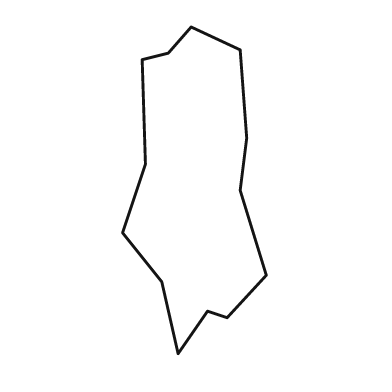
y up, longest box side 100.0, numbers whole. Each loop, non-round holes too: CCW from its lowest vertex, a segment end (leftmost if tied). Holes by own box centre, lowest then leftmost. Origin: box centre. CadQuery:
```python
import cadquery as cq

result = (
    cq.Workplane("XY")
    .moveTo(-5.0, -50.0)
    .lineTo(4.0, -37.0)
    .lineTo(10.0, -39.0)
    .lineTo(22.0, -26.0)
    .lineTo(14.0, 0.0)
    .lineTo(16.0, 16.0)
    .lineTo(14.0, 43.0)
    .lineTo(-1.0, 50.0)
    .lineTo(-8.0, 42.0)
    .lineTo(-16.0, 40.0)
    .lineTo(-15.0, 8.0)
    .lineTo(-22.0, -13.0)
    .lineTo(-10.0, -28.0)
    .close()
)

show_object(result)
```